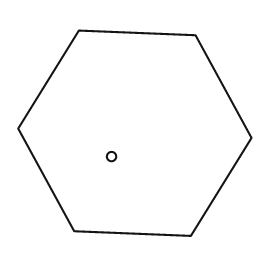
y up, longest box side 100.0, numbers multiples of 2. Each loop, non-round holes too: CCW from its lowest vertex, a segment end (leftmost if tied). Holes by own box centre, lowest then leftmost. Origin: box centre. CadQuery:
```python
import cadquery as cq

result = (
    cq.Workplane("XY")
    .moveTo(24.0, -44.0)
    .lineTo(50.0, -2.0)
    .lineTo(26.0, 42.0)
    .lineTo(-24.0, 44.0)
    .lineTo(-50.0, 2.0)
    .lineTo(-26.0, -42.0)
    .close()
    .moveTo(-10.0, -10.0)
    .circle(2.0)
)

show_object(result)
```